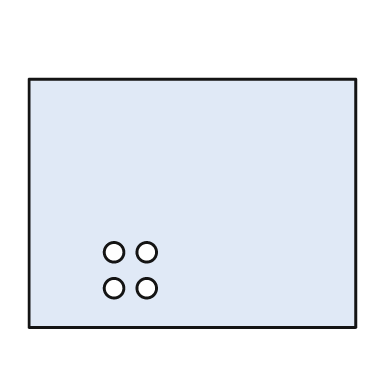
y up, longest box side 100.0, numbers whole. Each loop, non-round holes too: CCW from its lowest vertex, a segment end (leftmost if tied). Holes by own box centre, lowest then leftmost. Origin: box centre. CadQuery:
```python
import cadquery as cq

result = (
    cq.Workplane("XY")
    .moveTo(-50.0, -38.0)
    .lineTo(50.0, -38.0)
    .lineTo(50.0, 38.0)
    .lineTo(-50.0, 38.0)
    .close()
    .moveTo(-24.0, -26.0)
    .circle(3.0)
    .moveTo(-14.0, -26.0)
    .circle(3.0)
    .moveTo(-24.0, -15.0)
    .circle(3.0)
    .moveTo(-14.0, -15.0)
    .circle(3.0)
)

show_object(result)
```